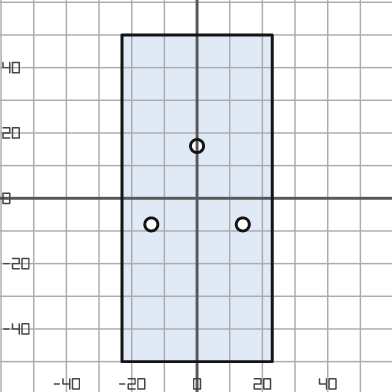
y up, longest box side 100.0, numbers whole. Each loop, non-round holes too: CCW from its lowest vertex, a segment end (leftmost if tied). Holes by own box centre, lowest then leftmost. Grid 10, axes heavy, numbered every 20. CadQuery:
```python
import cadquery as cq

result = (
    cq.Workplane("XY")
    .moveTo(-23.0, -50.0)
    .lineTo(23.0, -50.0)
    .lineTo(23.0, 50.0)
    .lineTo(-23.0, 50.0)
    .close()
    .moveTo(-14.0, -8.0)
    .circle(2.0)
    .moveTo(14.0, -8.0)
    .circle(2.0)
    .moveTo(0.0, 16.0)
    .circle(2.0)
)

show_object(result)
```